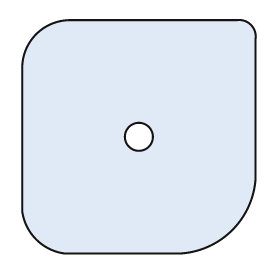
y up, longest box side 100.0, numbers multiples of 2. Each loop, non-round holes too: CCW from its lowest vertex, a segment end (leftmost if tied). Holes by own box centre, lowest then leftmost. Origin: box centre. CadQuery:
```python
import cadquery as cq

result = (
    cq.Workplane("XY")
    .moveTo(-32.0, -50.0)
    .lineTo(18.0, -50.0)
    .threePointArc((40.0, -40.0), (50.0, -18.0))
    .lineTo(50.0, 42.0)
    .threePointArc((48.0, 48.0), (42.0, 50.0))
    .lineTo(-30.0, 50.0)
    .threePointArc((-44.0, 44.0), (-50.0, 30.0))
    .lineTo(-50.0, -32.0)
    .threePointArc((-44.0, -44.0), (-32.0, -50.0))
    .close()
    .moveTo(0.0, 0.0)
    .circle(6.0)
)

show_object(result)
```